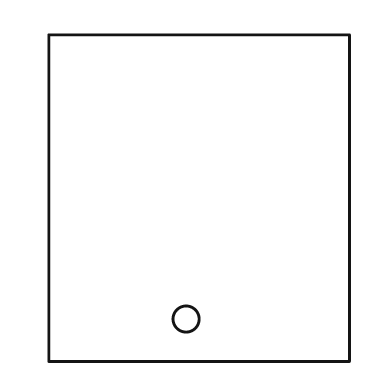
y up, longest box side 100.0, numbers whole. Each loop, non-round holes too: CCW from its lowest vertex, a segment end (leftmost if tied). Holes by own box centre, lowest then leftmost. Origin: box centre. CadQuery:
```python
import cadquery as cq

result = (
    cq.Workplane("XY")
    .moveTo(-46.0, -50.0)
    .lineTo(46.0, -50.0)
    .lineTo(46.0, 50.0)
    .lineTo(-46.0, 50.0)
    .close()
    .moveTo(-4.0, -37.0)
    .circle(4.0)
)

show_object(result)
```